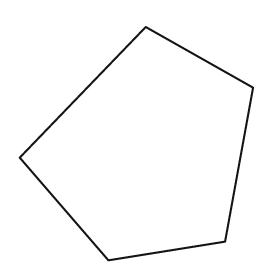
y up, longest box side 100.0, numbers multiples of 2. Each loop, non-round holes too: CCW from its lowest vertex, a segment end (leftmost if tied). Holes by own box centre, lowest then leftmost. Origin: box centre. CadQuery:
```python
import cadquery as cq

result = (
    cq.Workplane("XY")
    .moveTo(-12.0, -50.0)
    .lineTo(38.0, -42.0)
    .lineTo(50.0, 24.0)
    .lineTo(4.0, 50.0)
    .lineTo(-50.0, -6.0)
    .close()
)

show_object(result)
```